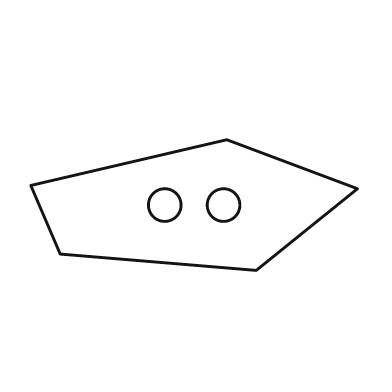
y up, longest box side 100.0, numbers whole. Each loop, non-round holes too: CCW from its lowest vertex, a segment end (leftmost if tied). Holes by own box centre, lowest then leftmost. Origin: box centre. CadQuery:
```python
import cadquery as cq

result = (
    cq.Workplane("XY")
    .moveTo(19.0, -20.0)
    .lineTo(50.0, 5.0)
    .lineTo(10.0, 20.0)
    .lineTo(-50.0, 6.0)
    .lineTo(-41.0, -15.0)
    .close()
    .moveTo(-9.0, 0.0)
    .circle(5.0)
    .moveTo(9.0, 0.0)
    .circle(5.0)
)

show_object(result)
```